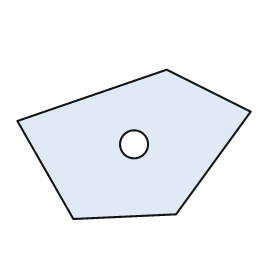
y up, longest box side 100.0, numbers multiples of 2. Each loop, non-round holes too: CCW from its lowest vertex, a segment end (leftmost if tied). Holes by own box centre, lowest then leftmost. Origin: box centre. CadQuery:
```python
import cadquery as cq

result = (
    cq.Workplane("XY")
    .moveTo(-26.0, -32.0)
    .lineTo(18.0, -30.0)
    .lineTo(50.0, 14.0)
    .lineTo(14.0, 32.0)
    .lineTo(-50.0, 10.0)
    .close()
    .moveTo(0.0, 0.0)
    .circle(6.0)
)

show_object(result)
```